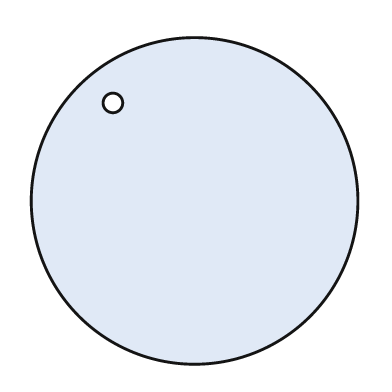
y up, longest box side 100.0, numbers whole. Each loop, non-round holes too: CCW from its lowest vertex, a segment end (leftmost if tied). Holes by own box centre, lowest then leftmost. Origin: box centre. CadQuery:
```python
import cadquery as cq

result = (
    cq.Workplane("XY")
    .moveTo(0.0, 0.0)
    .circle(50.0)
    .moveTo(-25.0, 30.0)
    .circle(3.0)
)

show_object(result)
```